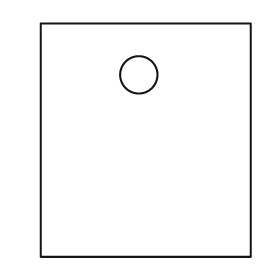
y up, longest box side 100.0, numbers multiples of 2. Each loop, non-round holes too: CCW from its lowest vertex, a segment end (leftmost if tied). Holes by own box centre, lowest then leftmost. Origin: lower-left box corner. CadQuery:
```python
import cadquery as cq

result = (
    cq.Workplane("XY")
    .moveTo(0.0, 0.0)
    .lineTo(90.0, 0.0)
    .lineTo(90.0, 100.0)
    .lineTo(0.0, 100.0)
    .close()
    .moveTo(42.0, 78.0)
    .circle(8.0)
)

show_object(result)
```